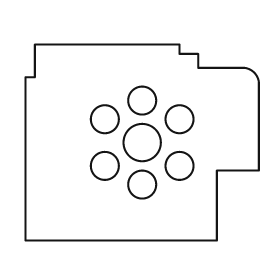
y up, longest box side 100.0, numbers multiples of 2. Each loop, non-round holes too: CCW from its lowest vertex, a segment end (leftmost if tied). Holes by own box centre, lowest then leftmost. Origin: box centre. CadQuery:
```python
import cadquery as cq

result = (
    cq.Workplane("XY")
    .moveTo(-50.0, -42.0)
    .lineTo(32.0, -42.0)
    .lineTo(32.0, -12.0)
    .lineTo(50.0, -12.0)
    .lineTo(50.0, 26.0)
    .threePointArc((48.0, 30.0), (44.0, 32.0))
    .lineTo(24.0, 32.0)
    .lineTo(24.0, 38.0)
    .lineTo(16.0, 38.0)
    .lineTo(16.0, 42.0)
    .lineTo(-46.0, 42.0)
    .lineTo(-46.0, 28.0)
    .lineTo(-50.0, 28.0)
    .close()
    .moveTo(0.0, -18.0)
    .circle(6.0)
    .moveTo(-16.0, -10.0)
    .circle(6.0)
    .moveTo(16.0, -10.0)
    .circle(6.0)
    .moveTo(0.0, 0.0)
    .circle(8.0)
    .moveTo(-16.0, 10.0)
    .circle(6.0)
    .moveTo(16.0, 10.0)
    .circle(6.0)
    .moveTo(0.0, 18.0)
    .circle(6.0)
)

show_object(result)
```